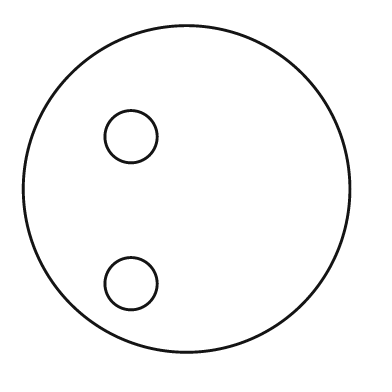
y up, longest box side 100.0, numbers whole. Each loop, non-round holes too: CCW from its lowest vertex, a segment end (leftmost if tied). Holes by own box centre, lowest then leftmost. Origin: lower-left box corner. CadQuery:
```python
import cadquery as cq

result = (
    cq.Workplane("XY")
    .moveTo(50.0, 50.0)
    .circle(50.0)
    .moveTo(33.0, 21.0)
    .circle(8.0)
    .moveTo(33.0, 66.0)
    .circle(8.0)
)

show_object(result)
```